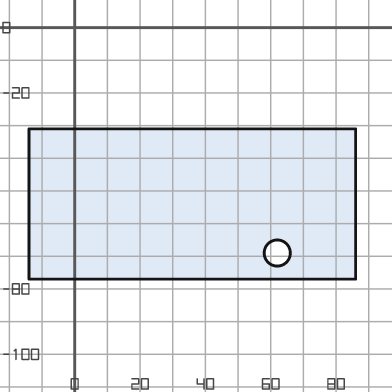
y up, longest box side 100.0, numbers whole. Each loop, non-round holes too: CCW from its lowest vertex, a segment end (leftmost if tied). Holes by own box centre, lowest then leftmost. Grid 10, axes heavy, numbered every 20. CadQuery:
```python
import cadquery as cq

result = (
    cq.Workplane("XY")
    .moveTo(-14.0, -77.0)
    .lineTo(86.0, -77.0)
    .lineTo(86.0, -31.0)
    .lineTo(-14.0, -31.0)
    .close()
    .moveTo(62.0, -69.0)
    .circle(4.0)
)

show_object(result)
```